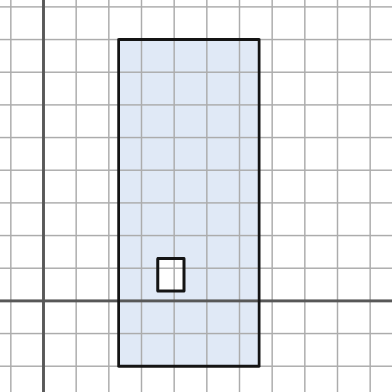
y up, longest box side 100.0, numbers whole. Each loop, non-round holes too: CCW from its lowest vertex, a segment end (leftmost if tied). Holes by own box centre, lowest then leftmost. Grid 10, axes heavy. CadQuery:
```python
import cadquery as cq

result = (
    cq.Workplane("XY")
    .moveTo(23.0, -20.0)
    .lineTo(66.0, -20.0)
    .lineTo(66.0, 80.0)
    .lineTo(23.0, 80.0)
    .close()
    .moveTo(35.0, 3.0)
    .lineTo(43.0, 3.0)
    .lineTo(43.0, 13.0)
    .lineTo(35.0, 13.0)
    .close()
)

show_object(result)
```